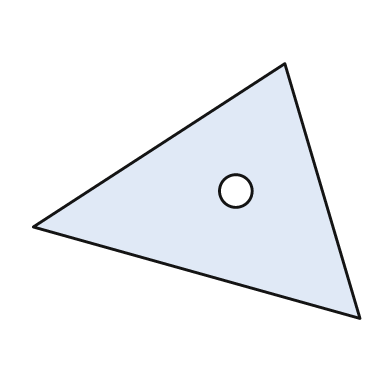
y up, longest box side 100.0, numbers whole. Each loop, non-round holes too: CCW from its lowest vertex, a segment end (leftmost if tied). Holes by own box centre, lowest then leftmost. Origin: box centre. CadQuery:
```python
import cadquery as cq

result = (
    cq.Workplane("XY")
    .moveTo(50.0, -39.0)
    .lineTo(27.0, 39.0)
    .lineTo(-50.0, -11.0)
    .close()
    .moveTo(12.0, 0.0)
    .circle(5.0)
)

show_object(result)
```